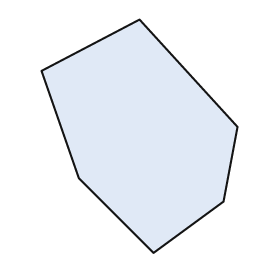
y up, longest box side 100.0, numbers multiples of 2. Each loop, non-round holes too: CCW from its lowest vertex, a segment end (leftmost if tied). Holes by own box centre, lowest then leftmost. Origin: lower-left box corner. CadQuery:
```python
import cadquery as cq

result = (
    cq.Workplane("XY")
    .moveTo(48.0, 0.0)
    .lineTo(78.0, 22.0)
    .lineTo(84.0, 54.0)
    .lineTo(42.0, 100.0)
    .lineTo(0.0, 78.0)
    .lineTo(16.0, 32.0)
    .close()
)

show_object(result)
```